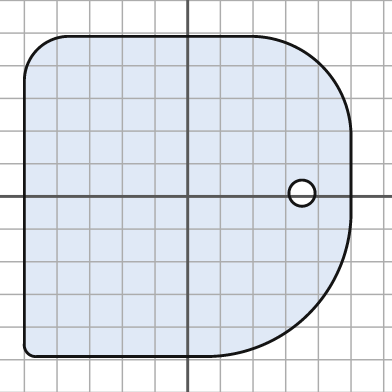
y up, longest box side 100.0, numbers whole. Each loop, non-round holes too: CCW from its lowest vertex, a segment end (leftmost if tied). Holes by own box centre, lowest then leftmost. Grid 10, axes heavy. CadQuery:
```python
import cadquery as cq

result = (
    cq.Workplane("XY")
    .moveTo(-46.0, -49.0)
    .lineTo(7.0, -49.0)
    .threePointArc((37.0, -36.0), (50.0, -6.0))
    .lineTo(50.0, 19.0)
    .threePointArc((41.0, 40.0), (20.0, 49.0))
    .lineTo(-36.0, 49.0)
    .threePointArc((-46.0, 45.0), (-50.0, 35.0))
    .lineTo(-50.0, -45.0)
    .threePointArc((-49.0, -48.0), (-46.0, -49.0))
    .close()
    .moveTo(35.0, 1.0)
    .circle(4.0)
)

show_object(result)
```